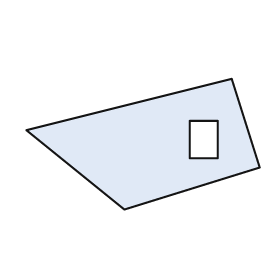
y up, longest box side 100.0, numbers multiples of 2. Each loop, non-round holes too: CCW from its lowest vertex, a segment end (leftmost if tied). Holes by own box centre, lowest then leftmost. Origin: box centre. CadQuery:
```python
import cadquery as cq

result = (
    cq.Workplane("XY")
    .moveTo(-8.0, -28.0)
    .lineTo(50.0, -10.0)
    .lineTo(38.0, 28.0)
    .lineTo(-50.0, 6.0)
    .close()
    .moveTo(20.0, -6.0)
    .lineTo(32.0, -6.0)
    .lineTo(32.0, 10.0)
    .lineTo(20.0, 10.0)
    .close()
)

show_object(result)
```